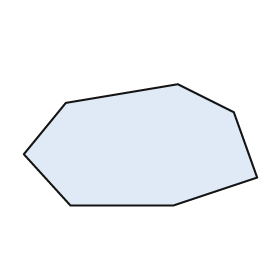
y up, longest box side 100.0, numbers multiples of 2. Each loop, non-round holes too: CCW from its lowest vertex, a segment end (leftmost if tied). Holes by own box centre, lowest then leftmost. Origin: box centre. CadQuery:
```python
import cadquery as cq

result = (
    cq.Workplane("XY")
    .moveTo(-30.0, -26.0)
    .lineTo(14.0, -26.0)
    .lineTo(50.0, -14.0)
    .lineTo(40.0, 14.0)
    .lineTo(16.0, 26.0)
    .lineTo(-32.0, 18.0)
    .lineTo(-50.0, -4.0)
    .close()
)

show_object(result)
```